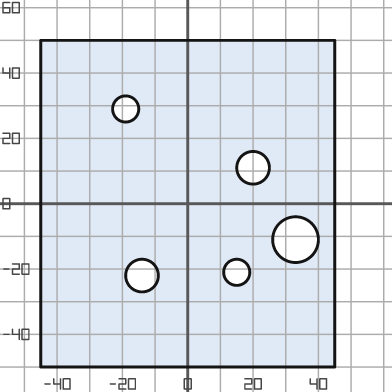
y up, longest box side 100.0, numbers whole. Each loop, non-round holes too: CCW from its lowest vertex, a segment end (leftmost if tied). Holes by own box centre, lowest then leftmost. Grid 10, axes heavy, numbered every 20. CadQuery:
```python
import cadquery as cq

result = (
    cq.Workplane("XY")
    .moveTo(-45.0, -50.0)
    .lineTo(45.0, -50.0)
    .lineTo(45.0, 50.0)
    .lineTo(-45.0, 50.0)
    .close()
    .moveTo(-14.0, -22.0)
    .circle(5.0)
    .moveTo(15.0, -21.0)
    .circle(4.0)
    .moveTo(33.0, -11.0)
    .circle(7.0)
    .moveTo(20.0, 11.0)
    .circle(5.0)
    .moveTo(-19.0, 29.0)
    .circle(4.0)
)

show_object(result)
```